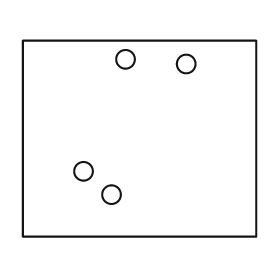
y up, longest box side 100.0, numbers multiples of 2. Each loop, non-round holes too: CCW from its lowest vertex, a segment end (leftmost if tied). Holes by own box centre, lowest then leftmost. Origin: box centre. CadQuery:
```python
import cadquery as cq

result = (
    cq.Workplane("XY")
    .moveTo(-50.0, -42.0)
    .lineTo(50.0, -42.0)
    .lineTo(50.0, 42.0)
    .lineTo(-50.0, 42.0)
    .close()
    .moveTo(-12.0, -24.0)
    .circle(4.0)
    .moveTo(-24.0, -14.0)
    .circle(4.0)
    .moveTo(20.0, 32.0)
    .circle(4.0)
    .moveTo(-6.0, 34.0)
    .circle(4.0)
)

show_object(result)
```